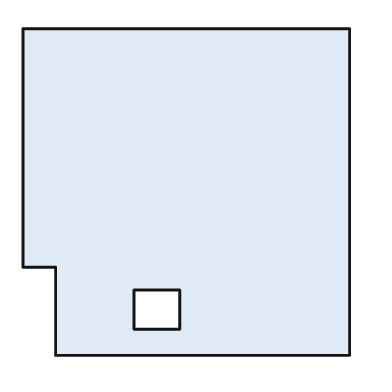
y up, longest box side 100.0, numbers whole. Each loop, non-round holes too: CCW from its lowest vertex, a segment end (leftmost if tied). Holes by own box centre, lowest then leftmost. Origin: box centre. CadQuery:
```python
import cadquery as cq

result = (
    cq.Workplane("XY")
    .moveTo(-40.0, -50.0)
    .lineTo(50.0, -50.0)
    .lineTo(50.0, 50.0)
    .lineTo(-50.0, 50.0)
    .lineTo(-50.0, -23.0)
    .lineTo(-40.0, -23.0)
    .close()
    .moveTo(-16.0, -42.0)
    .lineTo(-2.0, -42.0)
    .lineTo(-2.0, -30.0)
    .lineTo(-16.0, -30.0)
    .close()
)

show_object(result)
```